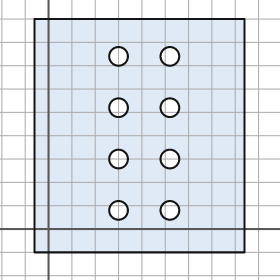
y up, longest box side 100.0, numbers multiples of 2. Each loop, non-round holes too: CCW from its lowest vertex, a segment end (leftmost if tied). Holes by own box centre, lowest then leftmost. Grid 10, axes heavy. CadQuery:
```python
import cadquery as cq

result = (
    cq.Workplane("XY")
    .moveTo(-6.0, -10.0)
    .lineTo(84.0, -10.0)
    .lineTo(84.0, 90.0)
    .lineTo(-6.0, 90.0)
    .close()
    .moveTo(30.0, 8.0)
    .circle(4.0)
    .moveTo(52.0, 8.0)
    .circle(4.0)
    .moveTo(30.0, 30.0)
    .circle(4.0)
    .moveTo(52.0, 30.0)
    .circle(4.0)
    .moveTo(30.0, 52.0)
    .circle(4.0)
    .moveTo(52.0, 52.0)
    .circle(4.0)
    .moveTo(30.0, 74.0)
    .circle(4.0)
    .moveTo(52.0, 74.0)
    .circle(4.0)
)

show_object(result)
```